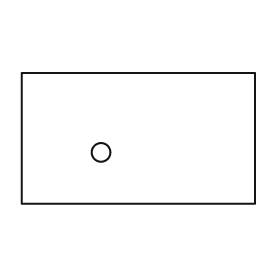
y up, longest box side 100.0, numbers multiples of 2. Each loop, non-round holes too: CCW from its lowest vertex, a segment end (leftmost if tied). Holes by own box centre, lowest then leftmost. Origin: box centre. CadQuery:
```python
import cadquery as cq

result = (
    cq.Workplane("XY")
    .moveTo(-50.0, -28.0)
    .lineTo(50.0, -28.0)
    .lineTo(50.0, 28.0)
    .lineTo(-50.0, 28.0)
    .close()
    .moveTo(-16.0, -6.0)
    .circle(4.0)
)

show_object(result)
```